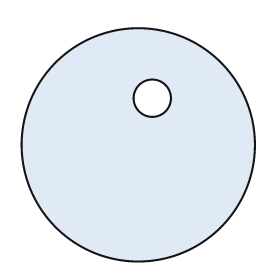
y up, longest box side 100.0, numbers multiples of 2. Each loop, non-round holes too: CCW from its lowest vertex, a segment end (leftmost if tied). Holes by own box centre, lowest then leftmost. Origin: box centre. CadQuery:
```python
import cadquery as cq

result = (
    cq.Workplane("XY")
    .moveTo(0.0, 0.0)
    .circle(50.0)
    .moveTo(6.0, 20.0)
    .circle(8.0)
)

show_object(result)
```